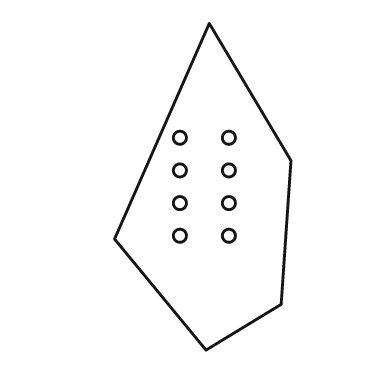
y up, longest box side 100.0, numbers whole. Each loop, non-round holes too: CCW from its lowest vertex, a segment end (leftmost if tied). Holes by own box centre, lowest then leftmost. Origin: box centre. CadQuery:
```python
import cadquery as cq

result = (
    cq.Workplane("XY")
    .moveTo(1.0, -50.0)
    .lineTo(24.0, -36.0)
    .lineTo(27.0, 8.0)
    .lineTo(2.0, 50.0)
    .lineTo(-27.0, -16.0)
    .close()
    .moveTo(-7.0, -15.0)
    .circle(2.0)
    .moveTo(8.0, -15.0)
    .circle(2.0)
    .moveTo(-7.0, -5.0)
    .circle(2.0)
    .moveTo(8.0, -5.0)
    .circle(2.0)
    .moveTo(-7.0, 5.0)
    .circle(2.0)
    .moveTo(8.0, 5.0)
    .circle(2.0)
    .moveTo(-7.0, 15.0)
    .circle(2.0)
    .moveTo(8.0, 15.0)
    .circle(2.0)
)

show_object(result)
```